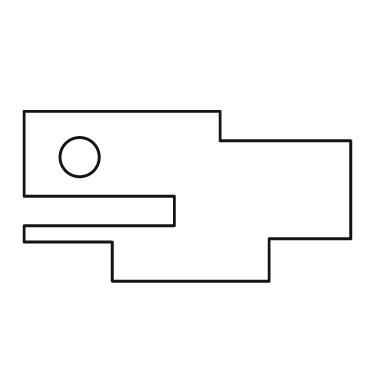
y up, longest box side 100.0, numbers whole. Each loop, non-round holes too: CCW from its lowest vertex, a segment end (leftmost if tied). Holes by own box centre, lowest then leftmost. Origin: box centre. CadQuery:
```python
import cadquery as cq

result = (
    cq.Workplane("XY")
    .moveTo(-23.0, -26.0)
    .lineTo(25.0, -26.0)
    .lineTo(25.0, -13.0)
    .lineTo(50.0, -13.0)
    .lineTo(50.0, 17.0)
    .lineTo(10.0, 17.0)
    .lineTo(10.0, 26.0)
    .lineTo(-50.0, 26.0)
    .lineTo(-50.0, 0.0)
    .lineTo(-4.0, 0.0)
    .lineTo(-4.0, -9.0)
    .lineTo(-50.0, -9.0)
    .lineTo(-50.0, -14.0)
    .lineTo(-23.0, -14.0)
    .close()
    .moveTo(-33.0, 12.0)
    .circle(6.0)
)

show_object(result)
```